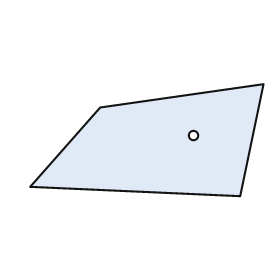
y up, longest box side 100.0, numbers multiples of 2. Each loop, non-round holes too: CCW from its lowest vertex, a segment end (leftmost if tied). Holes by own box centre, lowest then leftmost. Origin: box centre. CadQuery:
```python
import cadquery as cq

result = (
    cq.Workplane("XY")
    .moveTo(40.0, -24.0)
    .lineTo(50.0, 24.0)
    .lineTo(-20.0, 14.0)
    .lineTo(-50.0, -20.0)
    .close()
    .moveTo(20.0, 2.0)
    .circle(2.0)
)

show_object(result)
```